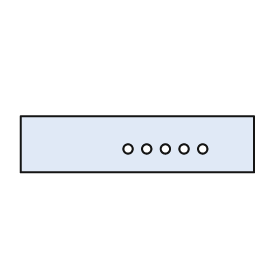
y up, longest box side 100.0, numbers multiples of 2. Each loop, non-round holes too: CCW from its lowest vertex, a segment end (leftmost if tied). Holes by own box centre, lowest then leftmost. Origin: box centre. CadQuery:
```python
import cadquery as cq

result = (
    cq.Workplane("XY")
    .moveTo(-50.0, -12.0)
    .lineTo(50.0, -12.0)
    .lineTo(50.0, 12.0)
    .lineTo(-50.0, 12.0)
    .close()
    .moveTo(-4.0, -2.0)
    .circle(2.0)
    .moveTo(4.0, -2.0)
    .circle(2.0)
    .moveTo(12.0, -2.0)
    .circle(2.0)
    .moveTo(20.0, -2.0)
    .circle(2.0)
    .moveTo(28.0, -2.0)
    .circle(2.0)
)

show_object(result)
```